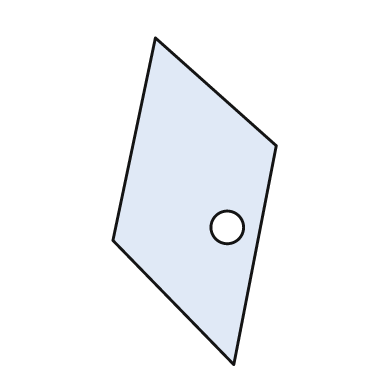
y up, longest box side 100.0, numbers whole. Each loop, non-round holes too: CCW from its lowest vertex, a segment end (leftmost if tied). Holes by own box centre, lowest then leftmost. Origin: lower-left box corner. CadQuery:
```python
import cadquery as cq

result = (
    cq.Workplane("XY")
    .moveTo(37.0, 0.0)
    .lineTo(50.0, 67.0)
    .lineTo(13.0, 100.0)
    .lineTo(0.0, 38.0)
    .close()
    .moveTo(35.0, 42.0)
    .circle(5.0)
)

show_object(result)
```